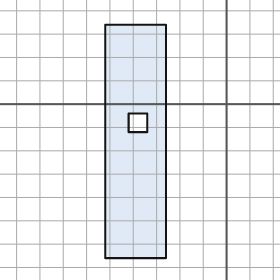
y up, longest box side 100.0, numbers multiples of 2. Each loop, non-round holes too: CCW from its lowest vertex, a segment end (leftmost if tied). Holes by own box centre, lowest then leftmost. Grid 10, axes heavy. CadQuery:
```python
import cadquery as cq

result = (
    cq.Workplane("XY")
    .moveTo(-52.0, -66.0)
    .lineTo(-26.0, -66.0)
    .lineTo(-26.0, 34.0)
    .lineTo(-52.0, 34.0)
    .close()
    .moveTo(-42.0, -12.0)
    .lineTo(-34.0, -12.0)
    .lineTo(-34.0, -4.0)
    .lineTo(-42.0, -4.0)
    .close()
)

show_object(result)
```